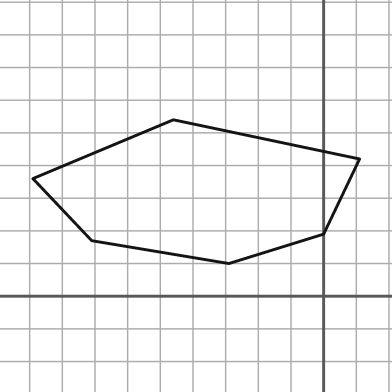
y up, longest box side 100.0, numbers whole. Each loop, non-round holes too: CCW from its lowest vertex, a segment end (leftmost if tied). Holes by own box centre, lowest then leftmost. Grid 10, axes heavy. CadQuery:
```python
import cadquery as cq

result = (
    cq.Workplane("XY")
    .moveTo(-29.0, 10.0)
    .lineTo(0.0, 19.0)
    .lineTo(11.0, 42.0)
    .lineTo(-46.0, 54.0)
    .lineTo(-89.0, 36.0)
    .lineTo(-71.0, 17.0)
    .close()
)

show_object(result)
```